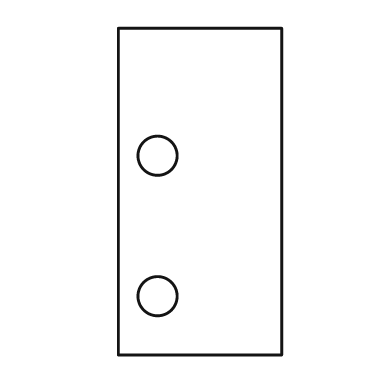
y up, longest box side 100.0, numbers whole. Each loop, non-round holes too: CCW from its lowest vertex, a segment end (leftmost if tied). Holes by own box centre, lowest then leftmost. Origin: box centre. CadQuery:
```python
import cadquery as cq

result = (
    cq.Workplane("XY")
    .moveTo(-25.0, -50.0)
    .lineTo(25.0, -50.0)
    .lineTo(25.0, 50.0)
    .lineTo(-25.0, 50.0)
    .close()
    .moveTo(-13.0, -32.0)
    .circle(6.0)
    .moveTo(-13.0, 11.0)
    .circle(6.0)
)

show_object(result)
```